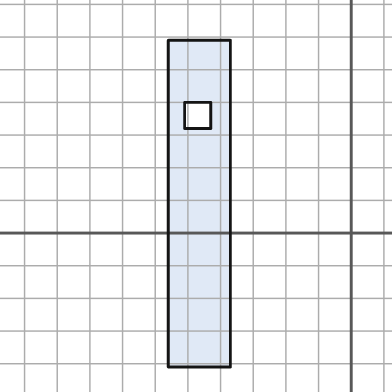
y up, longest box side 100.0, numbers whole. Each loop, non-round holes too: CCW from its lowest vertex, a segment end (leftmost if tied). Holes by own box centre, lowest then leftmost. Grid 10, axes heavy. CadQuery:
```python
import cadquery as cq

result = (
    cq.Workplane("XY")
    .moveTo(-56.0, -41.0)
    .lineTo(-37.0, -41.0)
    .lineTo(-37.0, 59.0)
    .lineTo(-56.0, 59.0)
    .close()
    .moveTo(-51.0, 32.0)
    .lineTo(-43.0, 32.0)
    .lineTo(-43.0, 40.0)
    .lineTo(-51.0, 40.0)
    .close()
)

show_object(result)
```